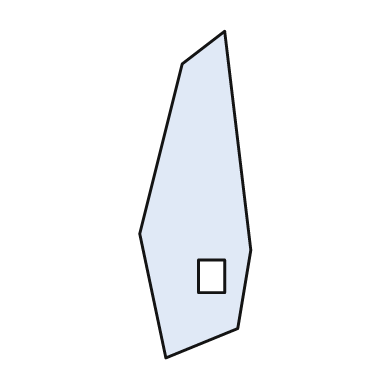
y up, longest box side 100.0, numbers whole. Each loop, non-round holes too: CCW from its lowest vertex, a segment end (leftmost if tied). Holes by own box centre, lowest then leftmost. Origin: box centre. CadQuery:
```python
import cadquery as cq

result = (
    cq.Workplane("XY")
    .moveTo(-9.0, -50.0)
    .lineTo(13.0, -41.0)
    .lineTo(17.0, -17.0)
    .lineTo(9.0, 50.0)
    .lineTo(-4.0, 40.0)
    .lineTo(-17.0, -12.0)
    .close()
    .moveTo(1.0, -30.0)
    .lineTo(9.0, -30.0)
    .lineTo(9.0, -20.0)
    .lineTo(1.0, -20.0)
    .close()
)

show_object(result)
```